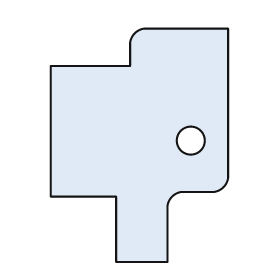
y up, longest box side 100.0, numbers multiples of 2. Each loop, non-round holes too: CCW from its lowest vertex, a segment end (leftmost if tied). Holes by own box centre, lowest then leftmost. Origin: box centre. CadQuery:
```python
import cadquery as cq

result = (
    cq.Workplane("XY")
    .moveTo(-10.0, -50.0)
    .lineTo(12.0, -50.0)
    .lineTo(12.0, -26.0)
    .threePointArc((14.0, -22.0), (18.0, -20.0))
    .lineTo(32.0, -20.0)
    .threePointArc((36.0, -18.0), (38.0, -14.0))
    .lineTo(38.0, 50.0)
    .lineTo(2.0, 50.0)
    .threePointArc((-2.0, 48.0), (-4.0, 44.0))
    .lineTo(-4.0, 34.0)
    .lineTo(-38.0, 34.0)
    .lineTo(-38.0, -22.0)
    .lineTo(-10.0, -22.0)
    .close()
    .moveTo(22.0, 2.0)
    .circle(6.0)
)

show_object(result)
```